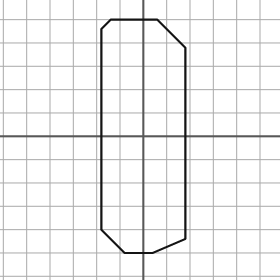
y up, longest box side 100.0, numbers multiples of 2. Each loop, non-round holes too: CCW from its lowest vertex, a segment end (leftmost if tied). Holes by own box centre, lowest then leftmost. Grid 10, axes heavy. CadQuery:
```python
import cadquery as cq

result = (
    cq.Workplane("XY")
    .moveTo(-8.0, -50.0)
    .lineTo(4.0, -50.0)
    .lineTo(18.0, -44.0)
    .lineTo(18.0, 38.0)
    .lineTo(6.0, 50.0)
    .lineTo(-14.0, 50.0)
    .lineTo(-18.0, 46.0)
    .lineTo(-18.0, -40.0)
    .close()
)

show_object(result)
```